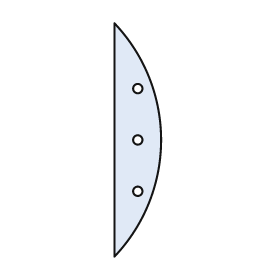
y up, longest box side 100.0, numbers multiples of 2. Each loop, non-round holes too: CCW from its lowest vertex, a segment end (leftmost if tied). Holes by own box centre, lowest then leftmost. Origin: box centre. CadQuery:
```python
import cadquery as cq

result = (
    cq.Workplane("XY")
    .moveTo(-10.0, -50.0)
    .threePointArc((10.0, 0.0), (-10.0, 50.0))
    .close()
    .moveTo(0.0, -22.0)
    .circle(2.0)
    .moveTo(0.0, 0.0)
    .circle(2.0)
    .moveTo(0.0, 22.0)
    .circle(2.0)
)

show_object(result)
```